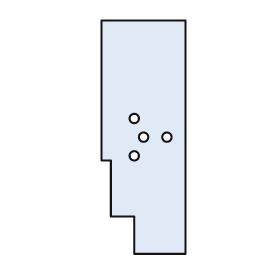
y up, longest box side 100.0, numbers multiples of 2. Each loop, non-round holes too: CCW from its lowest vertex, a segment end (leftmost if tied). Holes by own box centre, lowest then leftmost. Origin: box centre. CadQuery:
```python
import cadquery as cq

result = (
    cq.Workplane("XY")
    .moveTo(-4.0, -50.0)
    .lineTo(18.0, -50.0)
    .lineTo(18.0, 50.0)
    .lineTo(-18.0, 50.0)
    .lineTo(-18.0, -10.0)
    .lineTo(-14.0, -10.0)
    .lineTo(-14.0, -34.0)
    .lineTo(-4.0, -34.0)
    .close()
    .moveTo(-4.0, -8.0)
    .circle(2.0)
    .moveTo(0.0, 0.0)
    .circle(2.0)
    .moveTo(10.0, 0.0)
    .circle(2.0)
    .moveTo(-4.0, 8.0)
    .circle(2.0)
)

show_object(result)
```